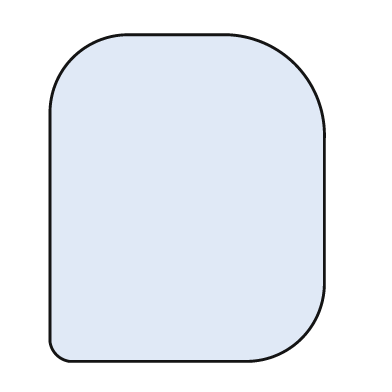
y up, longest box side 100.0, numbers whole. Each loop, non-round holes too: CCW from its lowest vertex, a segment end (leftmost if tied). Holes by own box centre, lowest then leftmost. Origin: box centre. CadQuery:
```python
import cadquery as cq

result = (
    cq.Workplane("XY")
    .moveTo(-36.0, -50.0)
    .lineTo(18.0, -50.0)
    .threePointArc((35.0, -43.0), (42.0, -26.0))
    .lineTo(42.0, 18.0)
    .threePointArc((33.0, 41.0), (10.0, 50.0))
    .lineTo(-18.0, 50.0)
    .threePointArc((-35.0, 43.0), (-42.0, 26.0))
    .lineTo(-42.0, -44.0)
    .threePointArc((-40.0, -48.0), (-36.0, -50.0))
    .close()
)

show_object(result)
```